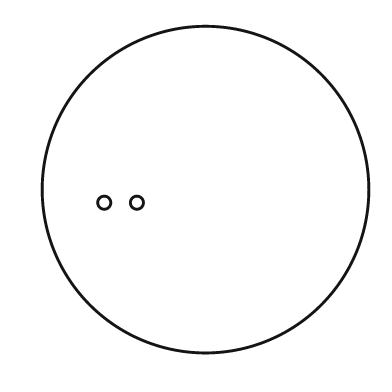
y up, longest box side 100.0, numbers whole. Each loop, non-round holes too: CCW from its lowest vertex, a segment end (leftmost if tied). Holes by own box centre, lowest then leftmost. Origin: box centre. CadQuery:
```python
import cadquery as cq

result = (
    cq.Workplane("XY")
    .moveTo(0.0, 0.0)
    .circle(50.0)
    .moveTo(-31.0, -4.0)
    .circle(2.0)
    .moveTo(-21.0, -4.0)
    .circle(2.0)
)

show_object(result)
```